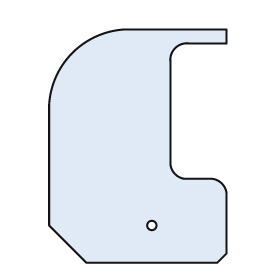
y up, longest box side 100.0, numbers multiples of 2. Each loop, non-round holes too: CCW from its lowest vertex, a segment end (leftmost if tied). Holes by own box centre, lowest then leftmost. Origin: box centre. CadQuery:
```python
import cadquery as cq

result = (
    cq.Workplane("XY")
    .moveTo(-22.0, -50.0)
    .lineTo(34.0, -50.0)
    .lineTo(38.0, -46.0)
    .lineTo(38.0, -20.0)
    .threePointArc((36.0, -16.0), (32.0, -14.0))
    .lineTo(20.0, -14.0)
    .threePointArc((16.0, -12.0), (14.0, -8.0))
    .lineTo(14.0, 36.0)
    .threePointArc((16.0, 42.0), (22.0, 44.0))
    .lineTo(38.0, 44.0)
    .lineTo(38.0, 50.0)
    .lineTo(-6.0, 50.0)
    .threePointArc((-28.0, 40.0), (-38.0, 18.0))
    .lineTo(-38.0, -34.0)
    .close()
    .moveTo(6.0, -34.0)
    .circle(2.0)
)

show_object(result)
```